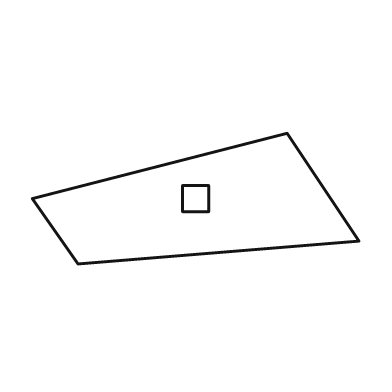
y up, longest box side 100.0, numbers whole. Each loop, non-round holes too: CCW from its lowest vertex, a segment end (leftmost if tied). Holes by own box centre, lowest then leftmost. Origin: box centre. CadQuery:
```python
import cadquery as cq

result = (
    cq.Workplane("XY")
    .moveTo(-36.0, -20.0)
    .lineTo(50.0, -13.0)
    .lineTo(28.0, 20.0)
    .lineTo(-50.0, 0.0)
    .close()
    .moveTo(-4.0, -4.0)
    .lineTo(4.0, -4.0)
    .lineTo(4.0, 4.0)
    .lineTo(-4.0, 4.0)
    .close()
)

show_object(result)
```